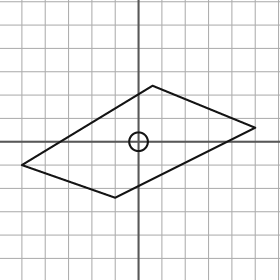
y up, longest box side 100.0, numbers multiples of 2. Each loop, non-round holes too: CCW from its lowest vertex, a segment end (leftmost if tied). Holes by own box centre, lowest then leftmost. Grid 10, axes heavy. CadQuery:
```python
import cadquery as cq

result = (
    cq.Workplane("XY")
    .moveTo(-10.0, -24.0)
    .lineTo(50.0, 6.0)
    .lineTo(6.0, 24.0)
    .lineTo(-50.0, -10.0)
    .close()
    .moveTo(0.0, 0.0)
    .circle(4.0)
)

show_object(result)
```